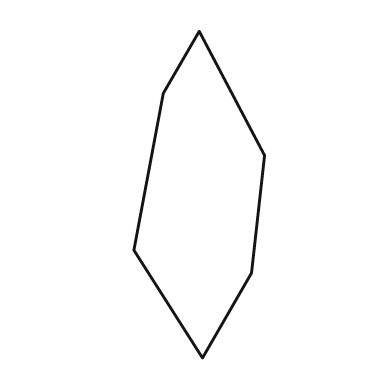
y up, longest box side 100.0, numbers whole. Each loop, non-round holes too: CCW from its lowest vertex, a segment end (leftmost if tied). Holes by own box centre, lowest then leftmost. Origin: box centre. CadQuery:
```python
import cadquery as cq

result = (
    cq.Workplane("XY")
    .moveTo(1.0, -50.0)
    .lineTo(16.0, -24.0)
    .lineTo(20.0, 12.0)
    .lineTo(0.0, 50.0)
    .lineTo(-11.0, 31.0)
    .lineTo(-20.0, -17.0)
    .close()
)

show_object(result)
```